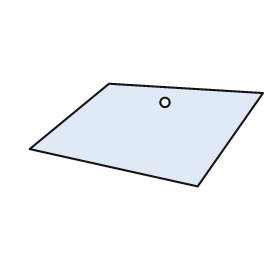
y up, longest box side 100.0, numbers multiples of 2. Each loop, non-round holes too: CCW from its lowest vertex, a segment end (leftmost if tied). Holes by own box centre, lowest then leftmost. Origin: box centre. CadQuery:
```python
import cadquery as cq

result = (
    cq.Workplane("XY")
    .moveTo(22.0, -22.0)
    .lineTo(50.0, 18.0)
    .lineTo(-16.0, 22.0)
    .lineTo(-50.0, -6.0)
    .close()
    .moveTo(8.0, 14.0)
    .circle(2.0)
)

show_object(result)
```